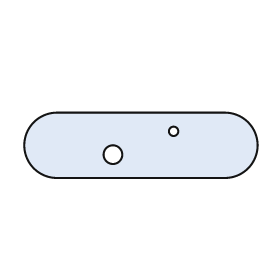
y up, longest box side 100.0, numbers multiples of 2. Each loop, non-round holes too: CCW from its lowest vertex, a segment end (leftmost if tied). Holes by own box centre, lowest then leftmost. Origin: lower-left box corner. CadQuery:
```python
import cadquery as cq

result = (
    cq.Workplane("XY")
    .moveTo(14.0, 0.0)
    .lineTo(86.0, 0.0)
    .threePointArc((100.0, 14.0), (86.0, 28.0))
    .lineTo(14.0, 28.0)
    .threePointArc((0.0, 14.0), (14.0, 0.0))
    .close()
    .moveTo(38.0, 10.0)
    .circle(4.0)
    .moveTo(64.0, 20.0)
    .circle(2.0)
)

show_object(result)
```